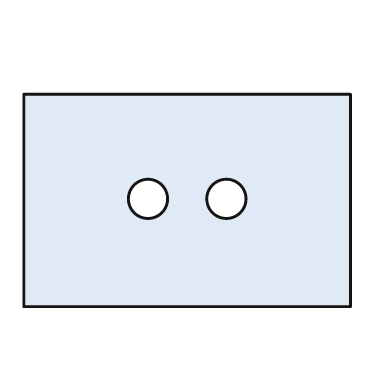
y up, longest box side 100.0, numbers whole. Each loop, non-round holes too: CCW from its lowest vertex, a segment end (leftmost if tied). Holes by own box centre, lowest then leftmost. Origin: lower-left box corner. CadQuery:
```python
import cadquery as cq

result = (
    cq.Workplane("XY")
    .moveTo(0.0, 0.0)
    .lineTo(100.0, 0.0)
    .lineTo(100.0, 65.0)
    .lineTo(0.0, 65.0)
    .close()
    .moveTo(38.0, 33.0)
    .circle(6.0)
    .moveTo(62.0, 33.0)
    .circle(6.0)
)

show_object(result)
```